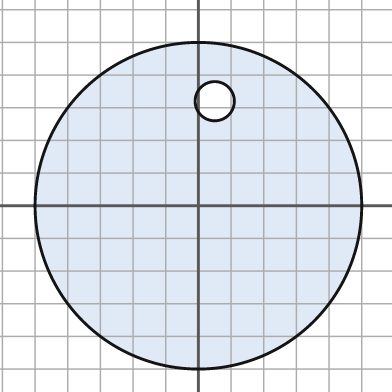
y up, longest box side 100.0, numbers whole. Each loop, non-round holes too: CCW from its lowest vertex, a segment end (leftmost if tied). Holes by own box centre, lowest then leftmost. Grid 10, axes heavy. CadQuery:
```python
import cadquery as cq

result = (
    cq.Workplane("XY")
    .moveTo(0.0, 0.0)
    .circle(50.0)
    .moveTo(5.0, 32.0)
    .circle(6.0)
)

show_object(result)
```